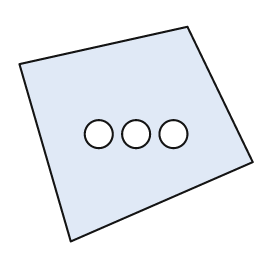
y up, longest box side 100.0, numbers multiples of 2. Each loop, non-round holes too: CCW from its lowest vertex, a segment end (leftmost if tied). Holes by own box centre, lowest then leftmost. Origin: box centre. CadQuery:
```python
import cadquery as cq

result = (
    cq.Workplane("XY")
    .moveTo(-28.0, -46.0)
    .lineTo(50.0, -12.0)
    .lineTo(22.0, 46.0)
    .lineTo(-50.0, 30.0)
    .close()
    .moveTo(-16.0, 0.0)
    .circle(6.0)
    .moveTo(0.0, 0.0)
    .circle(6.0)
    .moveTo(16.0, 0.0)
    .circle(6.0)
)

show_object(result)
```